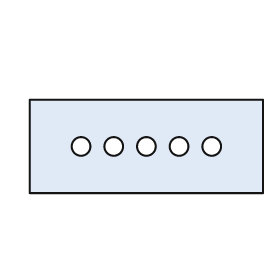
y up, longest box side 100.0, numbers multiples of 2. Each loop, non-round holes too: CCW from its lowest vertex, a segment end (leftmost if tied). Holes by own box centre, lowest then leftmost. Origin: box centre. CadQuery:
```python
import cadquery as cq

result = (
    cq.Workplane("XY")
    .moveTo(-50.0, -20.0)
    .lineTo(50.0, -20.0)
    .lineTo(50.0, 20.0)
    .lineTo(-50.0, 20.0)
    .close()
    .moveTo(-28.0, 0.0)
    .circle(4.0)
    .moveTo(-14.0, 0.0)
    .circle(4.0)
    .moveTo(0.0, 0.0)
    .circle(4.0)
    .moveTo(14.0, 0.0)
    .circle(4.0)
    .moveTo(28.0, 0.0)
    .circle(4.0)
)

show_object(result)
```